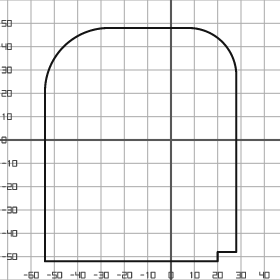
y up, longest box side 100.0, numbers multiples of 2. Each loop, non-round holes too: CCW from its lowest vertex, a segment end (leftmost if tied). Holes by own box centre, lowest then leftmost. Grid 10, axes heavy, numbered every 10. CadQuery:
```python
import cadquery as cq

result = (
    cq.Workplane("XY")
    .moveTo(-54.0, -52.0)
    .lineTo(20.0, -52.0)
    .lineTo(20.0, -48.0)
    .lineTo(28.0, -48.0)
    .lineTo(28.0, 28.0)
    .threePointArc((22.0, 42.0), (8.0, 48.0))
    .lineTo(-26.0, 48.0)
    .threePointArc((-46.0, 40.0), (-54.0, 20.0))
    .close()
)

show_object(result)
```